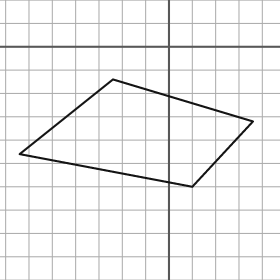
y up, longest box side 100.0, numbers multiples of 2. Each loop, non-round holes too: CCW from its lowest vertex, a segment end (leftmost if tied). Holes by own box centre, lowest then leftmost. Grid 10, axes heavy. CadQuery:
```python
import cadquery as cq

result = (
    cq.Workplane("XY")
    .moveTo(10.0, -60.0)
    .lineTo(36.0, -32.0)
    .lineTo(-24.0, -14.0)
    .lineTo(-64.0, -46.0)
    .close()
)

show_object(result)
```